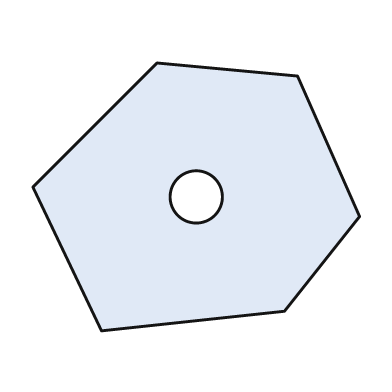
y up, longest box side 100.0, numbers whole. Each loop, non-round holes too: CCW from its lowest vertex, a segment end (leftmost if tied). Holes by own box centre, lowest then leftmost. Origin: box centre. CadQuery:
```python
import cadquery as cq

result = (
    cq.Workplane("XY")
    .moveTo(-29.0, -41.0)
    .lineTo(27.0, -35.0)
    .lineTo(50.0, -6.0)
    .lineTo(31.0, 37.0)
    .lineTo(-12.0, 41.0)
    .lineTo(-50.0, 3.0)
    .close()
    .moveTo(0.0, 0.0)
    .circle(8.0)
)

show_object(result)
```